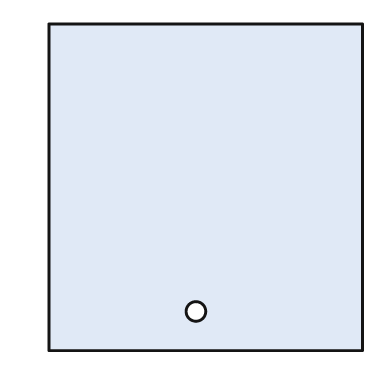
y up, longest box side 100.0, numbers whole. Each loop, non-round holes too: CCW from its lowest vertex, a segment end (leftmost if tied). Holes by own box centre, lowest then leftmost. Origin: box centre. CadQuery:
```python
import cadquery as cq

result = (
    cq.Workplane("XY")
    .moveTo(-48.0, -50.0)
    .lineTo(48.0, -50.0)
    .lineTo(48.0, 50.0)
    .lineTo(-48.0, 50.0)
    .close()
    .moveTo(-3.0, -38.0)
    .circle(3.0)
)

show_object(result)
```